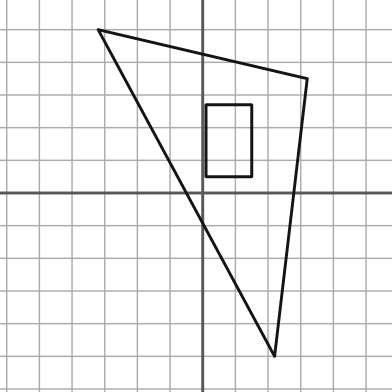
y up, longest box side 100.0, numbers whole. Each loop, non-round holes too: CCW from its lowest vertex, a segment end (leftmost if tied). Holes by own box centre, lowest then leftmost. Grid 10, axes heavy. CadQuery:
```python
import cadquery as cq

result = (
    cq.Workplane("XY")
    .moveTo(22.0, -50.0)
    .lineTo(32.0, 35.0)
    .lineTo(-32.0, 50.0)
    .close()
    .moveTo(1.0, 5.0)
    .lineTo(15.0, 5.0)
    .lineTo(15.0, 27.0)
    .lineTo(1.0, 27.0)
    .close()
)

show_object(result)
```